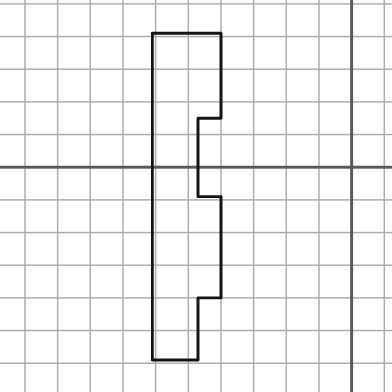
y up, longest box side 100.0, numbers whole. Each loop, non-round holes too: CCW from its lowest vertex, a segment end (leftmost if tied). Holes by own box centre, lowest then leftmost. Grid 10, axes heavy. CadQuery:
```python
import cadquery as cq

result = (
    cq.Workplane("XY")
    .moveTo(-61.0, -59.0)
    .lineTo(-47.0, -59.0)
    .lineTo(-47.0, -40.0)
    .lineTo(-40.0, -40.0)
    .lineTo(-40.0, -9.0)
    .lineTo(-47.0, -9.0)
    .lineTo(-47.0, 15.0)
    .lineTo(-40.0, 15.0)
    .lineTo(-40.0, 41.0)
    .lineTo(-61.0, 41.0)
    .close()
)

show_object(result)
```